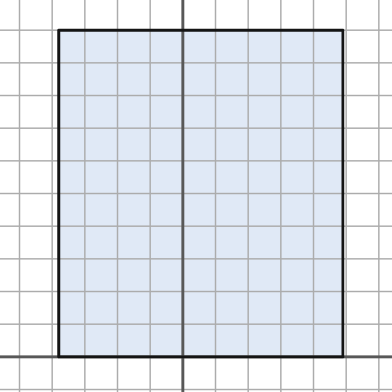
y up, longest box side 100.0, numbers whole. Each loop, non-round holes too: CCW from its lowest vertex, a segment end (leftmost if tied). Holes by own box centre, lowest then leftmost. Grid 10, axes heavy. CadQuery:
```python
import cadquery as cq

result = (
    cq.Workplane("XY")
    .moveTo(-38.0, 0.0)
    .lineTo(49.0, 0.0)
    .lineTo(49.0, 100.0)
    .lineTo(-38.0, 100.0)
    .close()
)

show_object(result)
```